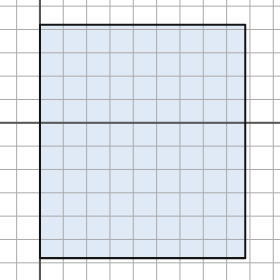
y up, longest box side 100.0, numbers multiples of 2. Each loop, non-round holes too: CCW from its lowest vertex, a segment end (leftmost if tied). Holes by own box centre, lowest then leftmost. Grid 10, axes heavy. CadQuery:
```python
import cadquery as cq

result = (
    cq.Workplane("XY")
    .moveTo(0.0, -58.0)
    .lineTo(88.0, -58.0)
    .lineTo(88.0, 42.0)
    .lineTo(0.0, 42.0)
    .close()
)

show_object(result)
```